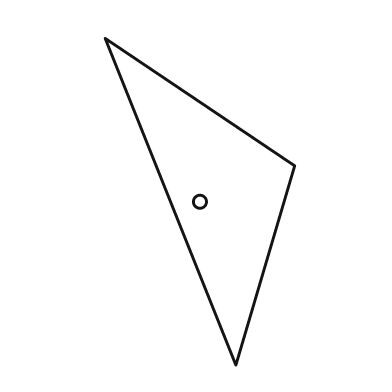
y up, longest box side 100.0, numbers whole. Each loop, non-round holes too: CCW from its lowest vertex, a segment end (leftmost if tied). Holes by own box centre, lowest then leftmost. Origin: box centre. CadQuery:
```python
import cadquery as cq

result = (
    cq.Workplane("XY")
    .moveTo(11.0, -50.0)
    .lineTo(29.0, 11.0)
    .lineTo(-29.0, 50.0)
    .close()
    .moveTo(0.0, 0.0)
    .circle(2.0)
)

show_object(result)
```